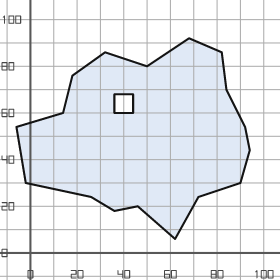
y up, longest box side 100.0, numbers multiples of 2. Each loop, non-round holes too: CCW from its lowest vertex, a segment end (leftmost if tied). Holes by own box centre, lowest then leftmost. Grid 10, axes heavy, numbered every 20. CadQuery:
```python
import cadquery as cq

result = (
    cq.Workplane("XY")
    .moveTo(62.0, 6.0)
    .lineTo(72.0, 24.0)
    .lineTo(90.0, 30.0)
    .lineTo(94.0, 44.0)
    .lineTo(92.0, 54.0)
    .lineTo(84.0, 70.0)
    .lineTo(82.0, 86.0)
    .lineTo(68.0, 92.0)
    .lineTo(50.0, 80.0)
    .lineTo(32.0, 86.0)
    .lineTo(18.0, 76.0)
    .lineTo(14.0, 60.0)
    .lineTo(-6.0, 54.0)
    .lineTo(-2.0, 30.0)
    .lineTo(26.0, 24.0)
    .lineTo(36.0, 18.0)
    .lineTo(46.0, 20.0)
    .close()
    .moveTo(36.0, 60.0)
    .lineTo(44.0, 60.0)
    .lineTo(44.0, 68.0)
    .lineTo(36.0, 68.0)
    .close()
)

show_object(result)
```